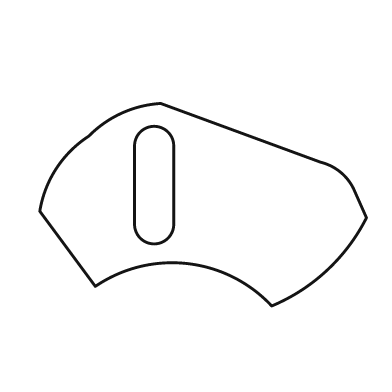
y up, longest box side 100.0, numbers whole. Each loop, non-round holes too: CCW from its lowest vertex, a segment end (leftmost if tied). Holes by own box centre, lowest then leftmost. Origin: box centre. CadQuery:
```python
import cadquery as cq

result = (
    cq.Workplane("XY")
    .moveTo(21.0, -31.0)
    .threePointArc((38.0, -20.0), (50.0, -4.0))
    .lineTo(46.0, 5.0)
    .threePointArc((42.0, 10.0), (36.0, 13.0))
    .lineTo(-13.0, 31.0)
    .threePointArc((-25.0, 28.0), (-35.0, 21.0))
    .threePointArc((-45.0, 11.0), (-50.0, -2.0))
    .lineTo(-33.0, -25.0)
    .threePointArc((-5.0, -18.0), (21.0, -31.0))
    .close()
    .moveTo(-21.0, -6.0)
    .threePointArc((-15.0, -12.0), (-9.0, -6.0))
    .lineTo(-9.0, 18.0)
    .threePointArc((-15.0, 24.0), (-21.0, 18.0))
    .close()
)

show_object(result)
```